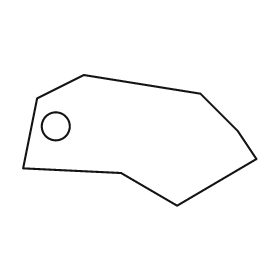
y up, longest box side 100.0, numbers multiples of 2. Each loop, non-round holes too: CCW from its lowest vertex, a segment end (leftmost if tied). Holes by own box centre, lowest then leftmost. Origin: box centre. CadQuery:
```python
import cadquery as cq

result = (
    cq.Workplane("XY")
    .moveTo(16.0, -28.0)
    .lineTo(50.0, -8.0)
    .lineTo(42.0, 4.0)
    .lineTo(26.0, 20.0)
    .lineTo(-24.0, 28.0)
    .lineTo(-44.0, 18.0)
    .lineTo(-50.0, -12.0)
    .lineTo(-8.0, -14.0)
    .close()
    .moveTo(-36.0, 6.0)
    .circle(6.0)
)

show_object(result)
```